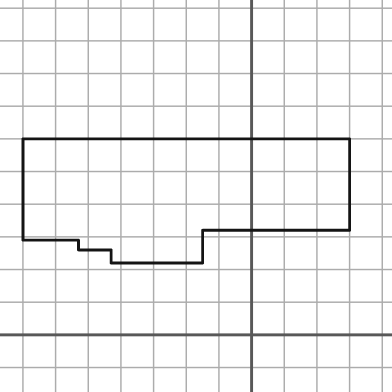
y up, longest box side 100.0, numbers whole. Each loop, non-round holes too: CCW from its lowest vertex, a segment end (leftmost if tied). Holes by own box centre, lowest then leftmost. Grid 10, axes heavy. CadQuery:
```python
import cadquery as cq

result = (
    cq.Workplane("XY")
    .moveTo(-43.0, 22.0)
    .lineTo(-15.0, 22.0)
    .lineTo(-15.0, 32.0)
    .lineTo(30.0, 32.0)
    .lineTo(30.0, 60.0)
    .lineTo(-70.0, 60.0)
    .lineTo(-70.0, 29.0)
    .lineTo(-53.0, 29.0)
    .lineTo(-53.0, 26.0)
    .lineTo(-43.0, 26.0)
    .close()
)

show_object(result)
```